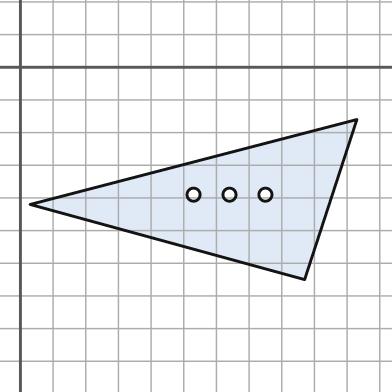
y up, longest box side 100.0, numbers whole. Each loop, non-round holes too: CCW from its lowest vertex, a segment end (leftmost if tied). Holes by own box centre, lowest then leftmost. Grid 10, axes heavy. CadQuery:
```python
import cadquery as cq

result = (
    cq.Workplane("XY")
    .moveTo(87.0, -65.0)
    .lineTo(103.0, -16.0)
    .lineTo(3.0, -42.0)
    .close()
    .moveTo(53.0, -39.0)
    .circle(2.0)
    .moveTo(64.0, -39.0)
    .circle(2.0)
    .moveTo(75.0, -39.0)
    .circle(2.0)
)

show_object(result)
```